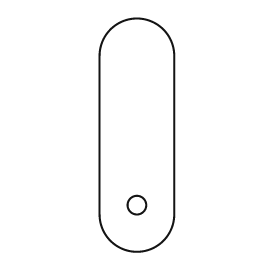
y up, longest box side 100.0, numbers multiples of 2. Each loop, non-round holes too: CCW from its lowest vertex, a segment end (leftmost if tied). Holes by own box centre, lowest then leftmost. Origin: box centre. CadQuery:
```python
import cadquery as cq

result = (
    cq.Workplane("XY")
    .moveTo(-16.0, -34.0)
    .threePointArc((0.0, -50.0), (16.0, -34.0))
    .lineTo(16.0, 34.0)
    .threePointArc((0.0, 50.0), (-16.0, 34.0))
    .close()
    .moveTo(0.0, -30.0)
    .circle(4.0)
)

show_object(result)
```